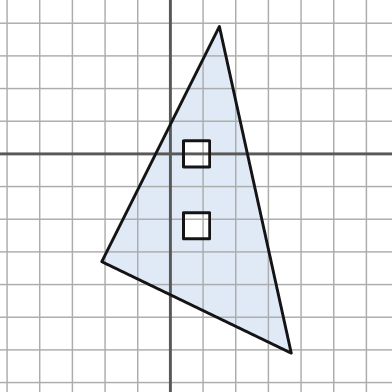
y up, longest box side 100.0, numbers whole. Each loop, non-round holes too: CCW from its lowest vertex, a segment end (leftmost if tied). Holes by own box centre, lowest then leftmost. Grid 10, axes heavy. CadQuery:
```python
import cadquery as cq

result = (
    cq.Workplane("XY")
    .moveTo(37.0, -61.0)
    .lineTo(15.0, 39.0)
    .lineTo(-21.0, -33.0)
    .close()
    .moveTo(4.0, -26.0)
    .lineTo(12.0, -26.0)
    .lineTo(12.0, -18.0)
    .lineTo(4.0, -18.0)
    .close()
    .moveTo(4.0, -4.0)
    .lineTo(12.0, -4.0)
    .lineTo(12.0, 4.0)
    .lineTo(4.0, 4.0)
    .close()
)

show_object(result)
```